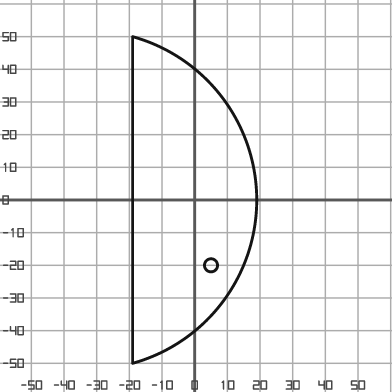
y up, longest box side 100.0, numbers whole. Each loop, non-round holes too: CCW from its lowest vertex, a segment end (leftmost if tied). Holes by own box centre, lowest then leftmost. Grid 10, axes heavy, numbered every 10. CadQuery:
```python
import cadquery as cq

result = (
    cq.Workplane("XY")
    .moveTo(-19.0, -50.0)
    .threePointArc((19.0, 0.0), (-19.0, 50.0))
    .close()
    .moveTo(5.0, -20.0)
    .circle(2.0)
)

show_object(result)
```